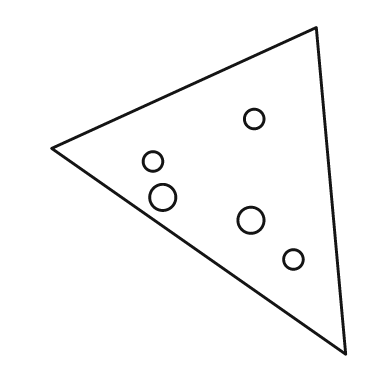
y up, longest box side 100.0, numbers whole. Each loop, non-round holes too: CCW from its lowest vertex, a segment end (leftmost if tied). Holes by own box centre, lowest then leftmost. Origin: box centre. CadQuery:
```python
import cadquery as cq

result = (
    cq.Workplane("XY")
    .moveTo(45.0, -50.0)
    .lineTo(36.0, 50.0)
    .lineTo(-45.0, 13.0)
    .close()
    .moveTo(29.0, -21.0)
    .circle(3.0)
    .moveTo(16.0, -9.0)
    .circle(4.0)
    .moveTo(-11.0, -2.0)
    .circle(4.0)
    .moveTo(-14.0, 9.0)
    .circle(3.0)
    .moveTo(17.0, 22.0)
    .circle(3.0)
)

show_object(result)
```